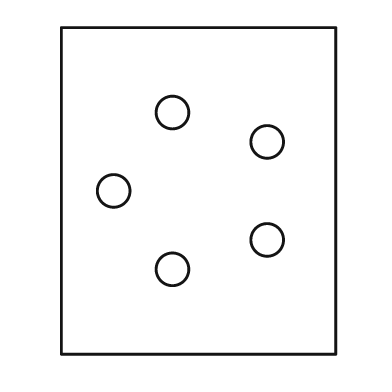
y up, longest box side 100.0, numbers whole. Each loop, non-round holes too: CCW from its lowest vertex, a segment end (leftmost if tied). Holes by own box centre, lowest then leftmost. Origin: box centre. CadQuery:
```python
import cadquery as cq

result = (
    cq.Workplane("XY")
    .moveTo(-42.0, -50.0)
    .lineTo(42.0, -50.0)
    .lineTo(42.0, 50.0)
    .lineTo(-42.0, 50.0)
    .close()
    .moveTo(-8.0, -24.0)
    .circle(5.0)
    .moveTo(21.0, -15.0)
    .circle(5.0)
    .moveTo(-26.0, 0.0)
    .circle(5.0)
    .moveTo(21.0, 15.0)
    .circle(5.0)
    .moveTo(-8.0, 24.0)
    .circle(5.0)
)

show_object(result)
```